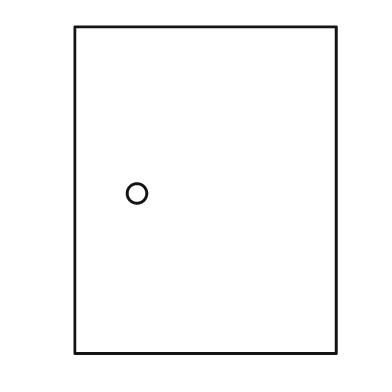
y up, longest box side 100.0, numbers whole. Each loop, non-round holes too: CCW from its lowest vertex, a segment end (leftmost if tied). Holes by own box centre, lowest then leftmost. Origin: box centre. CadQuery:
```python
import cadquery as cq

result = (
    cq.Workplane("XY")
    .moveTo(-40.0, -50.0)
    .lineTo(40.0, -50.0)
    .lineTo(40.0, 50.0)
    .lineTo(-40.0, 50.0)
    .close()
    .moveTo(-21.0, -1.0)
    .circle(3.0)
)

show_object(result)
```